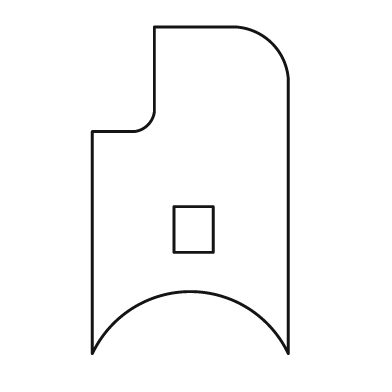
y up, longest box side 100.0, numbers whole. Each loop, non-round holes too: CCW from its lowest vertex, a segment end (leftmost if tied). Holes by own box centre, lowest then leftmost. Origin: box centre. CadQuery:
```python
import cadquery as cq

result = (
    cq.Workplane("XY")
    .moveTo(-30.0, -50.0)
    .threePointArc((0.0, -31.0), (30.0, -50.0))
    .lineTo(30.0, 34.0)
    .threePointArc((25.0, 45.0), (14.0, 50.0))
    .lineTo(-11.0, 50.0)
    .lineTo(-11.0, 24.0)
    .threePointArc((-13.0, 20.0), (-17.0, 18.0))
    .lineTo(-30.0, 18.0)
    .close()
    .moveTo(-5.0, -19.0)
    .lineTo(7.0, -19.0)
    .lineTo(7.0, -5.0)
    .lineTo(-5.0, -5.0)
    .close()
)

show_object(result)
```